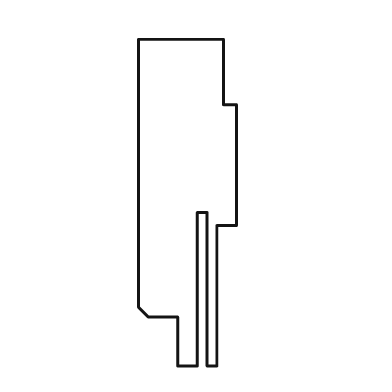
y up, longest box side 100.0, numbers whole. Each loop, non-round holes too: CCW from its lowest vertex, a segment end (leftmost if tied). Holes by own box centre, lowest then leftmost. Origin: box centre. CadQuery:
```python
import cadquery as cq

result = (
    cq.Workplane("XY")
    .moveTo(-3.0, -50.0)
    .lineTo(3.0, -50.0)
    .lineTo(3.0, -3.0)
    .lineTo(6.0, -3.0)
    .lineTo(6.0, -50.0)
    .lineTo(9.0, -50.0)
    .lineTo(9.0, -7.0)
    .lineTo(15.0, -7.0)
    .lineTo(15.0, 30.0)
    .lineTo(11.0, 30.0)
    .lineTo(11.0, 50.0)
    .lineTo(-15.0, 50.0)
    .lineTo(-15.0, -32.0)
    .lineTo(-12.0, -35.0)
    .lineTo(-3.0, -35.0)
    .close()
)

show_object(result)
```